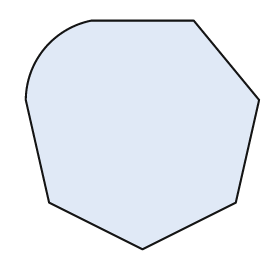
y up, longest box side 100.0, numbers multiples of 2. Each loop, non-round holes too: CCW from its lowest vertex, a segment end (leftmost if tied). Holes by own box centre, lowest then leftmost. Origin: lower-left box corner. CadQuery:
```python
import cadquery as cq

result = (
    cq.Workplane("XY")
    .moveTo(50.0, 0.0)
    .lineTo(90.0, 20.0)
    .lineTo(100.0, 64.0)
    .lineTo(72.0, 98.0)
    .lineTo(28.0, 98.0)
    .threePointArc((8.0, 86.0), (0.0, 64.0))
    .lineTo(10.0, 20.0)
    .close()
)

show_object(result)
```